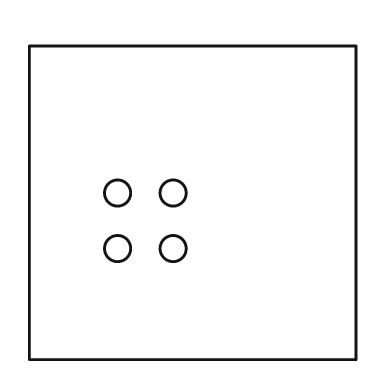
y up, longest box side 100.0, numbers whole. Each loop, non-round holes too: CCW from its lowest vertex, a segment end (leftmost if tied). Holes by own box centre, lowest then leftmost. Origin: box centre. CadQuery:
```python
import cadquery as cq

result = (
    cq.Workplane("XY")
    .moveTo(-50.0, -48.0)
    .lineTo(50.0, -48.0)
    .lineTo(50.0, 48.0)
    .lineTo(-50.0, 48.0)
    .close()
    .moveTo(-23.0, -14.0)
    .circle(4.0)
    .moveTo(-6.0, -14.0)
    .circle(4.0)
    .moveTo(-23.0, 3.0)
    .circle(4.0)
    .moveTo(-6.0, 3.0)
    .circle(4.0)
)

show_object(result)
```